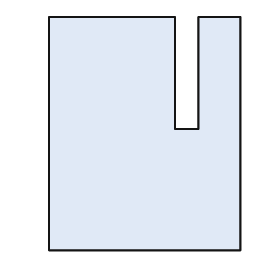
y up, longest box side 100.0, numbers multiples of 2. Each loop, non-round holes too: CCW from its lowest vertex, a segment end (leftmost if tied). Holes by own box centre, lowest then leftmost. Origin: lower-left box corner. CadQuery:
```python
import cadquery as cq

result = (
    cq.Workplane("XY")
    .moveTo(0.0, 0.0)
    .lineTo(82.0, 0.0)
    .lineTo(82.0, 100.0)
    .lineTo(64.0, 100.0)
    .lineTo(64.0, 52.0)
    .lineTo(54.0, 52.0)
    .lineTo(54.0, 100.0)
    .lineTo(0.0, 100.0)
    .close()
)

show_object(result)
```